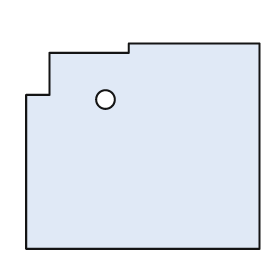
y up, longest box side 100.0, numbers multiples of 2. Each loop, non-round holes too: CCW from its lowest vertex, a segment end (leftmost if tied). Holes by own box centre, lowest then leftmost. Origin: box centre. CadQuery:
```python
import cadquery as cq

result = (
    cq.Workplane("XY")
    .moveTo(-50.0, -44.0)
    .lineTo(50.0, -44.0)
    .lineTo(50.0, 44.0)
    .lineTo(-6.0, 44.0)
    .lineTo(-6.0, 40.0)
    .lineTo(-40.0, 40.0)
    .lineTo(-40.0, 22.0)
    .lineTo(-50.0, 22.0)
    .close()
    .moveTo(-16.0, 20.0)
    .circle(4.0)
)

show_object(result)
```